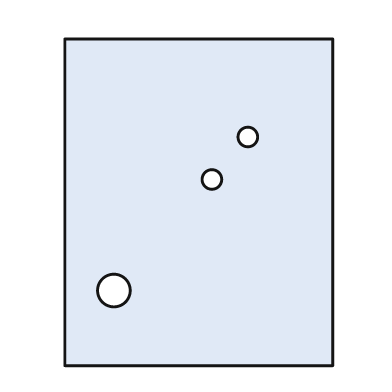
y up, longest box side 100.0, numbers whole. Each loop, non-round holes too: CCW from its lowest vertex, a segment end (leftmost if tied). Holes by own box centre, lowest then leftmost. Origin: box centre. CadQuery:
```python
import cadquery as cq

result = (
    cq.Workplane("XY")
    .moveTo(-41.0, -50.0)
    .lineTo(41.0, -50.0)
    .lineTo(41.0, 50.0)
    .lineTo(-41.0, 50.0)
    .close()
    .moveTo(-26.0, -27.0)
    .circle(5.0)
    .moveTo(4.0, 7.0)
    .circle(3.0)
    .moveTo(15.0, 20.0)
    .circle(3.0)
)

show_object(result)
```